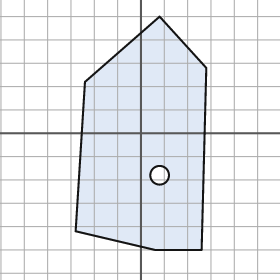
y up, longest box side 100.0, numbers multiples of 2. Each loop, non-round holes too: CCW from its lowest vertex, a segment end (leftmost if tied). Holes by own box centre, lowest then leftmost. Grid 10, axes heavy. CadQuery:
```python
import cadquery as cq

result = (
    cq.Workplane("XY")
    .moveTo(6.0, -50.0)
    .lineTo(26.0, -50.0)
    .lineTo(28.0, 28.0)
    .lineTo(8.0, 50.0)
    .lineTo(-24.0, 22.0)
    .lineTo(-28.0, -42.0)
    .close()
    .moveTo(8.0, -18.0)
    .circle(4.0)
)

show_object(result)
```